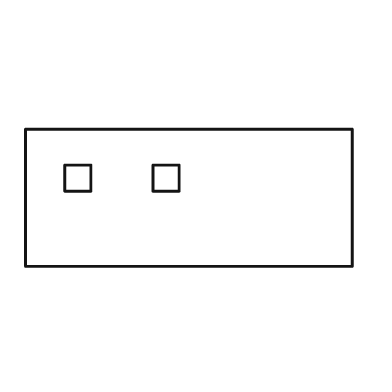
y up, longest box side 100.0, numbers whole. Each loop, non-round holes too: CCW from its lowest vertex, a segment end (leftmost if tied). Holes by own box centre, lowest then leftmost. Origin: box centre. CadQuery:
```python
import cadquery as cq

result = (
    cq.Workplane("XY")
    .moveTo(-50.0, -21.0)
    .lineTo(50.0, -21.0)
    .lineTo(50.0, 21.0)
    .lineTo(-50.0, 21.0)
    .close()
    .moveTo(-38.0, 2.0)
    .lineTo(-30.0, 2.0)
    .lineTo(-30.0, 10.0)
    .lineTo(-38.0, 10.0)
    .close()
    .moveTo(-11.0, 2.0)
    .lineTo(-3.0, 2.0)
    .lineTo(-3.0, 10.0)
    .lineTo(-11.0, 10.0)
    .close()
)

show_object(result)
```